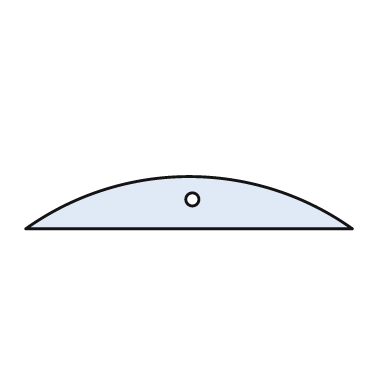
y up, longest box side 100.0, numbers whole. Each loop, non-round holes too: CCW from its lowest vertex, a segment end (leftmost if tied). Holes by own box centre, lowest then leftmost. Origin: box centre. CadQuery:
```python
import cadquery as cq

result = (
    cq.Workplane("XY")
    .moveTo(-50.0, -8.0)
    .lineTo(50.0, -8.0)
    .threePointArc((0.0, 8.0), (-50.0, -8.0))
    .close()
    .moveTo(1.0, 1.0)
    .circle(2.0)
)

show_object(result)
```